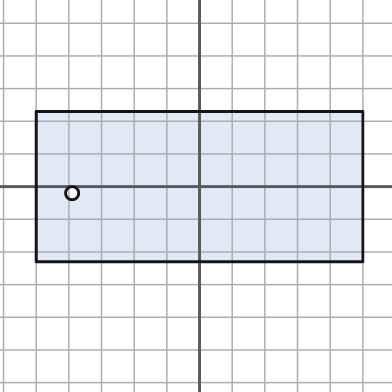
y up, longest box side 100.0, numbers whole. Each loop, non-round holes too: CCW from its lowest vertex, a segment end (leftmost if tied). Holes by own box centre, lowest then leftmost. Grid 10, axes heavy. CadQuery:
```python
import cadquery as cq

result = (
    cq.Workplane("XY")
    .moveTo(-50.0, -23.0)
    .lineTo(50.0, -23.0)
    .lineTo(50.0, 23.0)
    .lineTo(-50.0, 23.0)
    .close()
    .moveTo(-39.0, -2.0)
    .circle(2.0)
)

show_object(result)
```